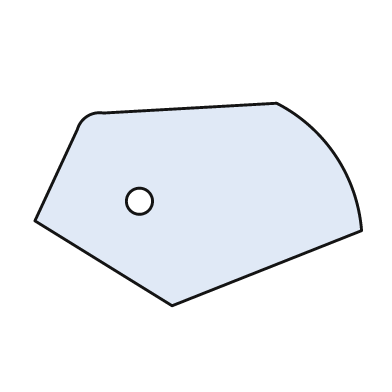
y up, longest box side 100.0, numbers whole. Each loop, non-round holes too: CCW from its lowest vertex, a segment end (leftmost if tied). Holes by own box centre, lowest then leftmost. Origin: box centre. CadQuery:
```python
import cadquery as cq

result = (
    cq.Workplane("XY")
    .moveTo(-8.0, -31.0)
    .lineTo(50.0, -8.0)
    .threePointArc((42.0, 15.0), (24.0, 31.0))
    .lineTo(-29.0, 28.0)
    .threePointArc((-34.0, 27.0), (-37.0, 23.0))
    .lineTo(-50.0, -5.0)
    .close()
    .moveTo(-18.0, 1.0)
    .circle(4.0)
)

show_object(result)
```